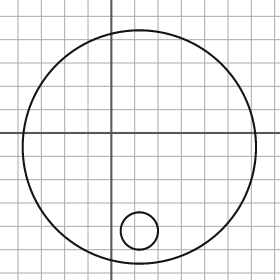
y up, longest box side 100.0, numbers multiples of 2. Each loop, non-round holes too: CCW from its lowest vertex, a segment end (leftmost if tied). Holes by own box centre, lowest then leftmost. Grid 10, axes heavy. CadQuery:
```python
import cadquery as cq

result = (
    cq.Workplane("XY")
    .moveTo(12.0, -6.0)
    .circle(50.0)
    .moveTo(12.0, -42.0)
    .circle(8.0)
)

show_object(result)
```